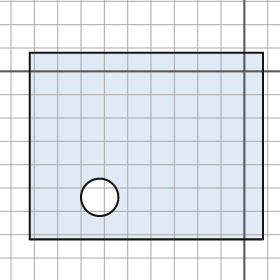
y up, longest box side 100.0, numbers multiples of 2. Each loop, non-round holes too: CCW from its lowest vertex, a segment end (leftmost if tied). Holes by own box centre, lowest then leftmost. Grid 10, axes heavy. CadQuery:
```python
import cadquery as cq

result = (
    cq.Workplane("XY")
    .moveTo(-92.0, -72.0)
    .lineTo(8.0, -72.0)
    .lineTo(8.0, 8.0)
    .lineTo(-92.0, 8.0)
    .close()
    .moveTo(-62.0, -54.0)
    .circle(8.0)
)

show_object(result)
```